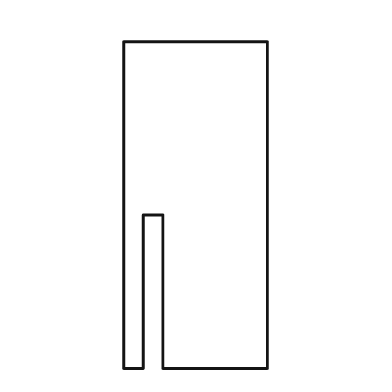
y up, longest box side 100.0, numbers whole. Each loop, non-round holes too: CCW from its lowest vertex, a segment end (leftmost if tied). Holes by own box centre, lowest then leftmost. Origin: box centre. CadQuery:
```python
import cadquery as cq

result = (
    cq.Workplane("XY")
    .moveTo(-22.0, -50.0)
    .lineTo(-16.0, -50.0)
    .lineTo(-16.0, -3.0)
    .lineTo(-10.0, -3.0)
    .lineTo(-10.0, -50.0)
    .lineTo(22.0, -50.0)
    .lineTo(22.0, 50.0)
    .lineTo(-22.0, 50.0)
    .close()
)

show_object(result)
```